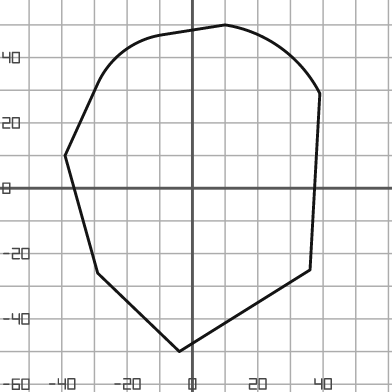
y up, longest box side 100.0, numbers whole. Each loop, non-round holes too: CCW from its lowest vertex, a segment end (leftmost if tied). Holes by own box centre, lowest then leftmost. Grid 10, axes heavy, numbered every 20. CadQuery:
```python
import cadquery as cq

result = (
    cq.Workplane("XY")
    .moveTo(-4.0, -50.0)
    .lineTo(36.0, -25.0)
    .lineTo(39.0, 29.0)
    .threePointArc((27.0, 43.0), (10.0, 50.0))
    .lineTo(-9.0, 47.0)
    .threePointArc((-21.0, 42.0), (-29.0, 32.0))
    .lineTo(-39.0, 10.0)
    .lineTo(-29.0, -26.0)
    .close()
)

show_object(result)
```